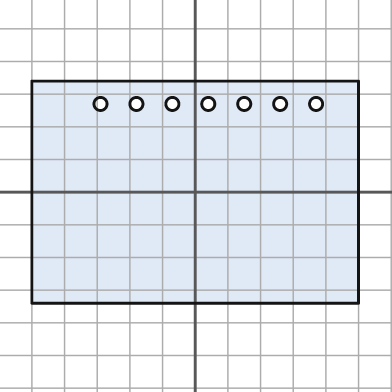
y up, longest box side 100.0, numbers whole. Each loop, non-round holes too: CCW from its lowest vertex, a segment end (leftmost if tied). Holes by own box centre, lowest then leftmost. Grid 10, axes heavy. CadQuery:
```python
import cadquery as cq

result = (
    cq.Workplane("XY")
    .moveTo(-50.0, -34.0)
    .lineTo(50.0, -34.0)
    .lineTo(50.0, 34.0)
    .lineTo(-50.0, 34.0)
    .close()
    .moveTo(-29.0, 27.0)
    .circle(2.0)
    .moveTo(-18.0, 27.0)
    .circle(2.0)
    .moveTo(-7.0, 27.0)
    .circle(2.0)
    .moveTo(4.0, 27.0)
    .circle(2.0)
    .moveTo(15.0, 27.0)
    .circle(2.0)
    .moveTo(26.0, 27.0)
    .circle(2.0)
    .moveTo(37.0, 27.0)
    .circle(2.0)
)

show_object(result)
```